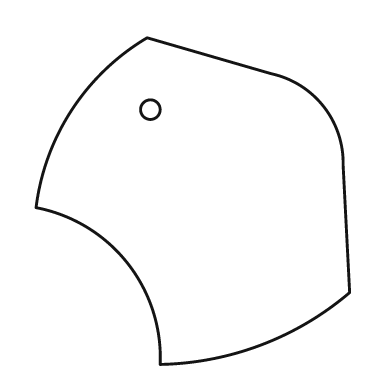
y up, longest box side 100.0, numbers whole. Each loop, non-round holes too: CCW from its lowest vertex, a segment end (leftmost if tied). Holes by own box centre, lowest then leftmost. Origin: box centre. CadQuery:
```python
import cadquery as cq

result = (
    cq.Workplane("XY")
    .moveTo(-10.0, -50.0)
    .threePointArc((21.0, -44.0), (48.0, -28.0))
    .lineTo(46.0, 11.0)
    .threePointArc((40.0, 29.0), (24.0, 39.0))
    .lineTo(-14.0, 50.0)
    .threePointArc((-37.0, 28.0), (-48.0, -2.0))
    .threePointArc((-20.0, -19.0), (-10.0, -50.0))
    .close()
    .moveTo(-13.0, 28.0)
    .circle(3.0)
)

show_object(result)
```